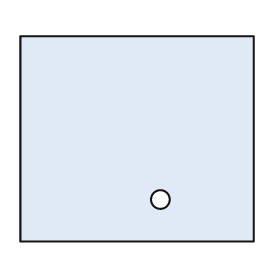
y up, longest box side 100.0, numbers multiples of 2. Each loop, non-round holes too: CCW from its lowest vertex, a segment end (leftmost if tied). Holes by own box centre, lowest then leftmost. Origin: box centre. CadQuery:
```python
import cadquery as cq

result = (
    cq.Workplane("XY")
    .moveTo(-50.0, -44.0)
    .lineTo(50.0, -44.0)
    .lineTo(50.0, 44.0)
    .lineTo(-50.0, 44.0)
    .close()
    .moveTo(10.0, -26.0)
    .circle(4.0)
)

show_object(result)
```